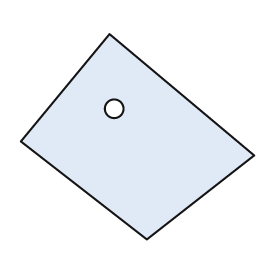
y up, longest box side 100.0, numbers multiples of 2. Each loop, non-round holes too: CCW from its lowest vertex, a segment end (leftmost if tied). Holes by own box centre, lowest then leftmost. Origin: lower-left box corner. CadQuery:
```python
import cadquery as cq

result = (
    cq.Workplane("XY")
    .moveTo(54.0, 0.0)
    .lineTo(100.0, 36.0)
    .lineTo(38.0, 88.0)
    .lineTo(0.0, 42.0)
    .close()
    .moveTo(40.0, 56.0)
    .circle(4.0)
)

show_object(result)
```